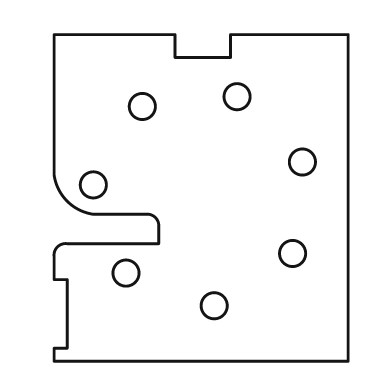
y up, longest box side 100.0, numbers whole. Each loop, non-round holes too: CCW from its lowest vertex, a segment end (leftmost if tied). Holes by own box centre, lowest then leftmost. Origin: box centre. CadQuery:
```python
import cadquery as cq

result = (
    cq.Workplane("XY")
    .moveTo(-45.0, -50.0)
    .lineTo(45.0, -50.0)
    .lineTo(45.0, 50.0)
    .lineTo(9.0, 50.0)
    .lineTo(9.0, 43.0)
    .lineTo(-8.0, 43.0)
    .lineTo(-8.0, 50.0)
    .lineTo(-45.0, 50.0)
    .lineTo(-45.0, 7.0)
    .threePointArc((-41.0, -1.0), (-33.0, -5.0))
    .lineTo(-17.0, -5.0)
    .threePointArc((-14.0, -6.0), (-13.0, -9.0))
    .lineTo(-13.0, -14.0)
    .lineTo(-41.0, -14.0)
    .threePointArc((-44.0, -15.0), (-45.0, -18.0))
    .lineTo(-45.0, -25.0)
    .lineTo(-41.0, -25.0)
    .lineTo(-41.0, -46.0)
    .lineTo(-45.0, -46.0)
    .close()
    .moveTo(4.0, -33.0)
    .circle(4.0)
    .moveTo(-23.0, -23.0)
    .circle(4.0)
    .moveTo(28.0, -17.0)
    .circle(4.0)
    .moveTo(-33.0, 4.0)
    .circle(4.0)
    .moveTo(31.0, 11.0)
    .circle(4.0)
    .moveTo(-18.0, 28.0)
    .circle(4.0)
    .moveTo(11.0, 31.0)
    .circle(4.0)
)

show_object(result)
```